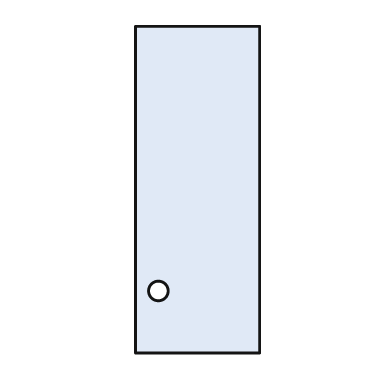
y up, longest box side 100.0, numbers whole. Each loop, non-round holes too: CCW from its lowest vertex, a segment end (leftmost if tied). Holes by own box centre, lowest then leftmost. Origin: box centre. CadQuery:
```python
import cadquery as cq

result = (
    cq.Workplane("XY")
    .moveTo(-19.0, -50.0)
    .lineTo(19.0, -50.0)
    .lineTo(19.0, 50.0)
    .lineTo(-19.0, 50.0)
    .close()
    .moveTo(-12.0, -31.0)
    .circle(3.0)
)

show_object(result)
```